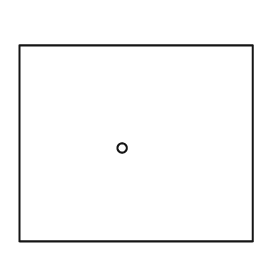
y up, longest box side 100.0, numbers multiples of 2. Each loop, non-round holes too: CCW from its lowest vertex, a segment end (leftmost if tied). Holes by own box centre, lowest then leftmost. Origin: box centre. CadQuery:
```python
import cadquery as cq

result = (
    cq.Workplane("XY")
    .moveTo(-50.0, -42.0)
    .lineTo(50.0, -42.0)
    .lineTo(50.0, 42.0)
    .lineTo(-50.0, 42.0)
    .close()
    .moveTo(-6.0, -2.0)
    .circle(2.0)
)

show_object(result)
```